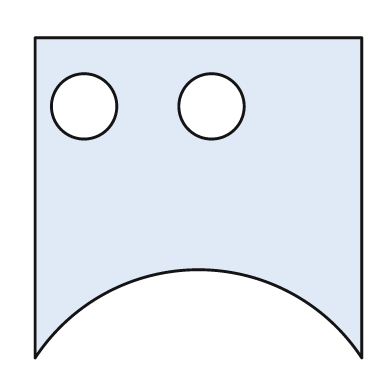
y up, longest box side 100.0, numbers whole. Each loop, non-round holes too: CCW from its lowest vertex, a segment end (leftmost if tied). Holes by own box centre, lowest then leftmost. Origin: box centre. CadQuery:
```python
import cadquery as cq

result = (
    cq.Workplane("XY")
    .moveTo(-50.0, -49.0)
    .threePointArc((0.0, -22.0), (50.0, -49.0))
    .lineTo(50.0, 49.0)
    .lineTo(-50.0, 49.0)
    .close()
    .moveTo(-35.0, 28.0)
    .circle(10.0)
    .moveTo(4.0, 28.0)
    .circle(10.0)
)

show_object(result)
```